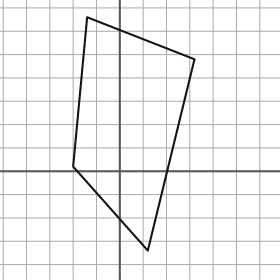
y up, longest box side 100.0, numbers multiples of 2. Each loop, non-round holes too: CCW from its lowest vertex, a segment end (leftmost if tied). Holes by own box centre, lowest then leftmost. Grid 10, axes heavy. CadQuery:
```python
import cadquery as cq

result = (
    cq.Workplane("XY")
    .moveTo(12.0, -34.0)
    .lineTo(32.0, 48.0)
    .lineTo(-14.0, 66.0)
    .lineTo(-20.0, 2.0)
    .close()
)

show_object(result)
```